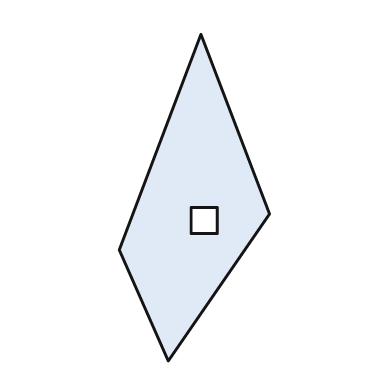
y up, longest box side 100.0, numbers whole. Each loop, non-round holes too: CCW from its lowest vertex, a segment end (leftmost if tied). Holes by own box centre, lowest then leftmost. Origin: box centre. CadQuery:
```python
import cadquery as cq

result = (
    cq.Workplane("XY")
    .moveTo(-8.0, -50.0)
    .lineTo(23.0, -5.0)
    .lineTo(2.0, 50.0)
    .lineTo(-23.0, -16.0)
    .close()
    .moveTo(-1.0, -11.0)
    .lineTo(7.0, -11.0)
    .lineTo(7.0, -3.0)
    .lineTo(-1.0, -3.0)
    .close()
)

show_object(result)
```